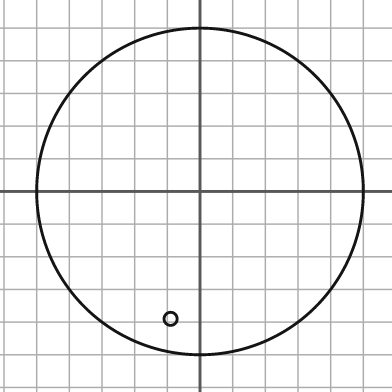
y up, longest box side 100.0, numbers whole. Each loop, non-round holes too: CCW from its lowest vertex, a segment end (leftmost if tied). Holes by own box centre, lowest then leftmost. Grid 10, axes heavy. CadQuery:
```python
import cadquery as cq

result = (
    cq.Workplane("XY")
    .moveTo(0.0, 0.0)
    .circle(50.0)
    .moveTo(-9.0, -39.0)
    .circle(2.0)
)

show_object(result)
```